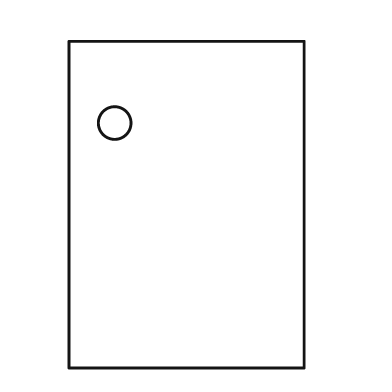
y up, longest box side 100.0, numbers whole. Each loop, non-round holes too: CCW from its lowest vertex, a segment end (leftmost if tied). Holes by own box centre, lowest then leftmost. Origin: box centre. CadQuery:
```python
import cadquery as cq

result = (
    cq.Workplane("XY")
    .moveTo(-36.0, -50.0)
    .lineTo(36.0, -50.0)
    .lineTo(36.0, 50.0)
    .lineTo(-36.0, 50.0)
    .close()
    .moveTo(-22.0, 25.0)
    .circle(5.0)
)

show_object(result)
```